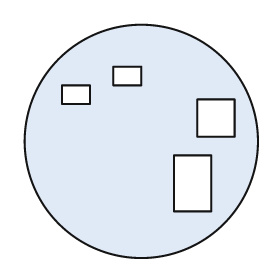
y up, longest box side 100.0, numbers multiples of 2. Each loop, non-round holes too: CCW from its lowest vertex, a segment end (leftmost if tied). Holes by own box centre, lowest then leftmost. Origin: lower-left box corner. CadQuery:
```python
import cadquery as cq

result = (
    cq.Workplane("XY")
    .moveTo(50.0, 50.0)
    .circle(50.0)
    .moveTo(64.0, 20.0)
    .lineTo(80.0, 20.0)
    .lineTo(80.0, 44.0)
    .lineTo(64.0, 44.0)
    .close()
    .moveTo(74.0, 52.0)
    .lineTo(90.0, 52.0)
    .lineTo(90.0, 68.0)
    .lineTo(74.0, 68.0)
    .close()
    .moveTo(16.0, 66.0)
    .lineTo(28.0, 66.0)
    .lineTo(28.0, 74.0)
    .lineTo(16.0, 74.0)
    .close()
    .moveTo(38.0, 74.0)
    .lineTo(50.0, 74.0)
    .lineTo(50.0, 82.0)
    .lineTo(38.0, 82.0)
    .close()
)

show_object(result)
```